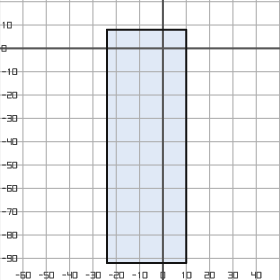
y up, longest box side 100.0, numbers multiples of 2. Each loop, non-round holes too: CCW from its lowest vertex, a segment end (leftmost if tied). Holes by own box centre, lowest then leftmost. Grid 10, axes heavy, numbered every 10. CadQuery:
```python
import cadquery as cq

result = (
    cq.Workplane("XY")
    .moveTo(-24.0, -92.0)
    .lineTo(10.0, -92.0)
    .lineTo(10.0, 8.0)
    .lineTo(-24.0, 8.0)
    .close()
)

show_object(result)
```